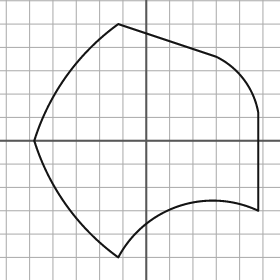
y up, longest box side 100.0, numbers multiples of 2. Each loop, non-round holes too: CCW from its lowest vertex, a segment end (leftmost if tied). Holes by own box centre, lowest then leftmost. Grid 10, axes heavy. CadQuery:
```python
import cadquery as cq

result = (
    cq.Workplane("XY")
    .moveTo(-12.0, -50.0)
    .threePointArc((14.0, -28.0), (48.0, -30.0))
    .lineTo(48.0, 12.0)
    .threePointArc((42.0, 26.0), (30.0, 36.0))
    .lineTo(-12.0, 50.0)
    .threePointArc((-34.0, 28.0), (-48.0, 0.0))
    .threePointArc((-34.0, -28.0), (-12.0, -50.0))
    .close()
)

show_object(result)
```